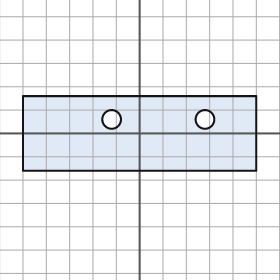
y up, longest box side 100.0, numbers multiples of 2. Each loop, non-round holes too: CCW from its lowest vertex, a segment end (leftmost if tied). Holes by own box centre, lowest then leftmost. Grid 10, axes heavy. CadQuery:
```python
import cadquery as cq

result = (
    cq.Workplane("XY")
    .moveTo(-50.0, -16.0)
    .lineTo(50.0, -16.0)
    .lineTo(50.0, 16.0)
    .lineTo(-50.0, 16.0)
    .close()
    .moveTo(-12.0, 6.0)
    .circle(4.0)
    .moveTo(28.0, 6.0)
    .circle(4.0)
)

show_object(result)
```